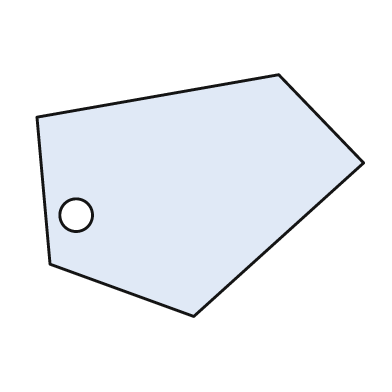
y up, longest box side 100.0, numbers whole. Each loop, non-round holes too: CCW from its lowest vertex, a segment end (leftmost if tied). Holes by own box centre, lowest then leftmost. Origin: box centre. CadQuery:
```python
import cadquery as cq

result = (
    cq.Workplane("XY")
    .moveTo(-2.0, -37.0)
    .lineTo(50.0, 10.0)
    .lineTo(24.0, 37.0)
    .lineTo(-50.0, 24.0)
    .lineTo(-46.0, -21.0)
    .close()
    .moveTo(-38.0, -6.0)
    .circle(5.0)
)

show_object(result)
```